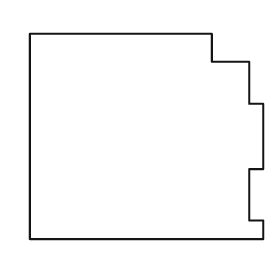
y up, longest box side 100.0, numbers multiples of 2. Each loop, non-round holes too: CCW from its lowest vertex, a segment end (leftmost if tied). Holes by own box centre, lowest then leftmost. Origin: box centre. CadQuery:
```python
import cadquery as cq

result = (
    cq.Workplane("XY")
    .moveTo(-50.0, -44.0)
    .lineTo(50.0, -44.0)
    .lineTo(50.0, -36.0)
    .lineTo(44.0, -36.0)
    .lineTo(44.0, -14.0)
    .lineTo(50.0, -14.0)
    .lineTo(50.0, 14.0)
    .lineTo(44.0, 14.0)
    .lineTo(44.0, 32.0)
    .lineTo(28.0, 32.0)
    .lineTo(28.0, 44.0)
    .lineTo(-50.0, 44.0)
    .close()
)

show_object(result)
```